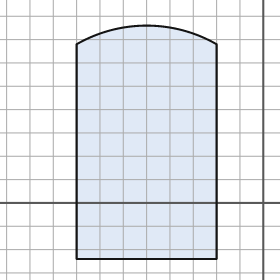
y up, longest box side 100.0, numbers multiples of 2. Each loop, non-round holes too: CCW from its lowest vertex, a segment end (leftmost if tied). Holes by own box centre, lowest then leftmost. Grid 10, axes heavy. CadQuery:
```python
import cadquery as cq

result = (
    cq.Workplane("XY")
    .moveTo(-80.0, -24.0)
    .lineTo(-20.0, -24.0)
    .lineTo(-20.0, 68.0)
    .threePointArc((-50.0, 76.0), (-80.0, 68.0))
    .close()
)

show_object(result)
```